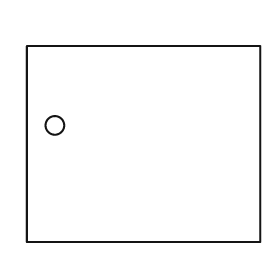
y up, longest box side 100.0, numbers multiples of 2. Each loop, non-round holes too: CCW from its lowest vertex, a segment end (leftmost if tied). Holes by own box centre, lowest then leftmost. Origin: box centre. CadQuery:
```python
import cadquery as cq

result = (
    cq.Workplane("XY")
    .moveTo(-50.0, -42.0)
    .lineTo(50.0, -42.0)
    .lineTo(50.0, 42.0)
    .lineTo(-50.0, 42.0)
    .close()
    .moveTo(-38.0, 8.0)
    .circle(4.0)
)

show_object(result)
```